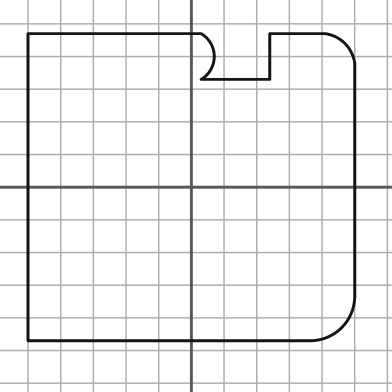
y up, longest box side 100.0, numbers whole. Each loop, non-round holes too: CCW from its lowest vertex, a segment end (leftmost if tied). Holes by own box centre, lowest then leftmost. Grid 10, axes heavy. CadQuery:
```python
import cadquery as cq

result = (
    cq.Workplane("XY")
    .moveTo(-50.0, -47.0)
    .lineTo(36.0, -47.0)
    .threePointArc((46.0, -43.0), (50.0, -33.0))
    .lineTo(50.0, 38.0)
    .threePointArc((47.0, 44.0), (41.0, 47.0))
    .lineTo(24.0, 47.0)
    .lineTo(24.0, 33.0)
    .lineTo(3.0, 33.0)
    .threePointArc((7.0, 40.0), (3.0, 47.0))
    .lineTo(-50.0, 47.0)
    .close()
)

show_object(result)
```